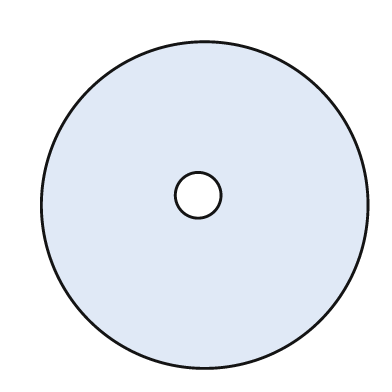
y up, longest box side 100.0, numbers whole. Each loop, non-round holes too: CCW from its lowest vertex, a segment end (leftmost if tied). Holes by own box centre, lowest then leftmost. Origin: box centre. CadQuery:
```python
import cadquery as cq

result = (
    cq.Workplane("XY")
    .moveTo(0.0, 0.0)
    .circle(50.0)
    .moveTo(-2.0, 3.0)
    .circle(7.0)
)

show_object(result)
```